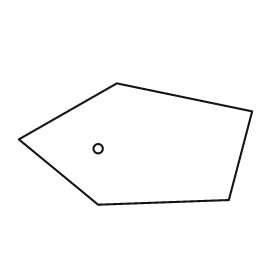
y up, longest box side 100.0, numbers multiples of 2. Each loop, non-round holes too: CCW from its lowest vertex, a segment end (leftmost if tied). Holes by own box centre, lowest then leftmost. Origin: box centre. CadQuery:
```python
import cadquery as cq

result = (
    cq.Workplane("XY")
    .moveTo(-16.0, -26.0)
    .lineTo(40.0, -24.0)
    .lineTo(50.0, 14.0)
    .lineTo(-8.0, 26.0)
    .lineTo(-50.0, 2.0)
    .close()
    .moveTo(-16.0, -2.0)
    .circle(2.0)
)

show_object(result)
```